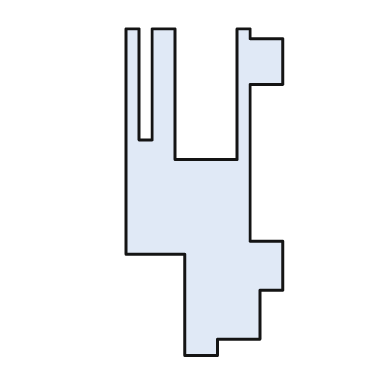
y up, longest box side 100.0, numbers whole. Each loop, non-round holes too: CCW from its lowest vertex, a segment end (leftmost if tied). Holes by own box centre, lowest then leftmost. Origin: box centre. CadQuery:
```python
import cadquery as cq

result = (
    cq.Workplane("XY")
    .moveTo(-6.0, -50.0)
    .lineTo(4.0, -50.0)
    .lineTo(4.0, -45.0)
    .lineTo(17.0, -45.0)
    .lineTo(17.0, -30.0)
    .lineTo(24.0, -30.0)
    .lineTo(24.0, -15.0)
    .lineTo(14.0, -15.0)
    .lineTo(14.0, 33.0)
    .lineTo(24.0, 33.0)
    .lineTo(24.0, 47.0)
    .lineTo(14.0, 47.0)
    .lineTo(14.0, 50.0)
    .lineTo(10.0, 50.0)
    .lineTo(10.0, 10.0)
    .lineTo(-9.0, 10.0)
    .lineTo(-9.0, 50.0)
    .lineTo(-16.0, 50.0)
    .lineTo(-16.0, 16.0)
    .lineTo(-20.0, 16.0)
    .lineTo(-20.0, 50.0)
    .lineTo(-24.0, 50.0)
    .lineTo(-24.0, -19.0)
    .lineTo(-6.0, -19.0)
    .close()
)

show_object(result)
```